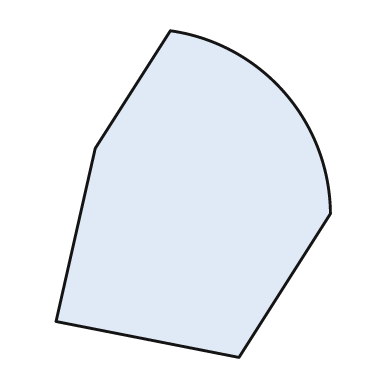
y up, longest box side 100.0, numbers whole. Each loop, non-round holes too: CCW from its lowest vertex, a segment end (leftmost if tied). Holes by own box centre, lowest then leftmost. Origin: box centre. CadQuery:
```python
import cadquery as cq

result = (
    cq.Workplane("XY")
    .moveTo(14.0, -50.0)
    .lineTo(42.0, -6.0)
    .threePointArc((28.0, 31.0), (-7.0, 50.0))
    .lineTo(-30.0, 14.0)
    .lineTo(-42.0, -39.0)
    .close()
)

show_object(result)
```